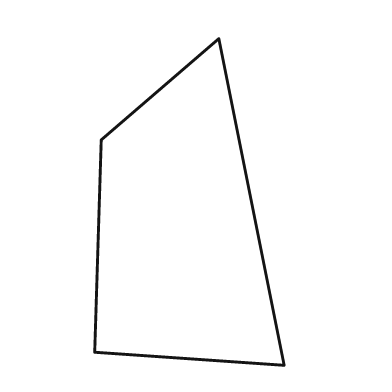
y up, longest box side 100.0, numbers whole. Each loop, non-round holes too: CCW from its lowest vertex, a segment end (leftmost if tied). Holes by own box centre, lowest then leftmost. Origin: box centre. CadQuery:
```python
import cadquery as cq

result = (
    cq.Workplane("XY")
    .moveTo(29.0, -50.0)
    .lineTo(9.0, 50.0)
    .lineTo(-27.0, 19.0)
    .lineTo(-29.0, -46.0)
    .close()
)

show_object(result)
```